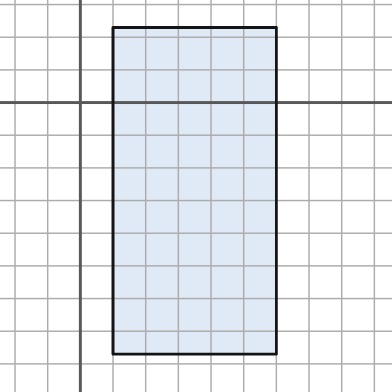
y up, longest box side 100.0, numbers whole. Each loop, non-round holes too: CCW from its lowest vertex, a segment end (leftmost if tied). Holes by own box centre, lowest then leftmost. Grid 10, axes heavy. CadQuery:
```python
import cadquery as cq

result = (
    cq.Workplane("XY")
    .moveTo(10.0, -77.0)
    .lineTo(60.0, -77.0)
    .lineTo(60.0, 23.0)
    .lineTo(10.0, 23.0)
    .close()
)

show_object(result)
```